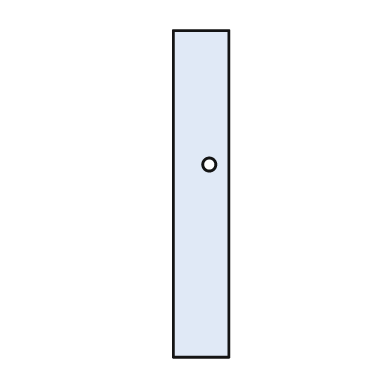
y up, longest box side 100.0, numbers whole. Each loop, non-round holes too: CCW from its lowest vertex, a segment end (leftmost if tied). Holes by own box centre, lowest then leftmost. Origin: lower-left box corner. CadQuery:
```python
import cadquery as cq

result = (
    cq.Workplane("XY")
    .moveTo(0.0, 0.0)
    .lineTo(17.0, 0.0)
    .lineTo(17.0, 100.0)
    .lineTo(0.0, 100.0)
    .close()
    .moveTo(11.0, 59.0)
    .circle(2.0)
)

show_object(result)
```